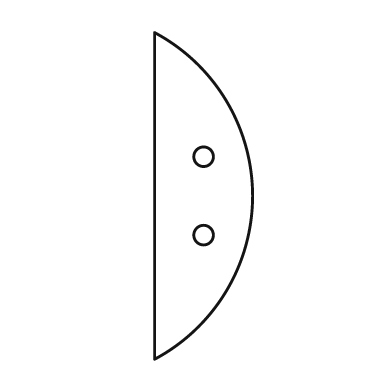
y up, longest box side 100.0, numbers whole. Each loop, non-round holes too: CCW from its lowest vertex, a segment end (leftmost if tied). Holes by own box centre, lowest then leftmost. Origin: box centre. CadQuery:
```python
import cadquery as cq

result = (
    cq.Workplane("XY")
    .moveTo(-15.0, -50.0)
    .threePointArc((15.0, 0.0), (-15.0, 50.0))
    .close()
    .moveTo(0.0, -12.0)
    .circle(3.0)
    .moveTo(0.0, 12.0)
    .circle(3.0)
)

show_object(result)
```